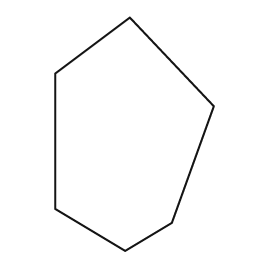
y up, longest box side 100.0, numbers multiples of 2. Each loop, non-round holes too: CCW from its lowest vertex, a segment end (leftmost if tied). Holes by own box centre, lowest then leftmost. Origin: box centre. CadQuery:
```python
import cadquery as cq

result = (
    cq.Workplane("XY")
    .moveTo(-4.0, -50.0)
    .lineTo(16.0, -38.0)
    .lineTo(34.0, 12.0)
    .lineTo(-2.0, 50.0)
    .lineTo(-34.0, 26.0)
    .lineTo(-34.0, -32.0)
    .close()
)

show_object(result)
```